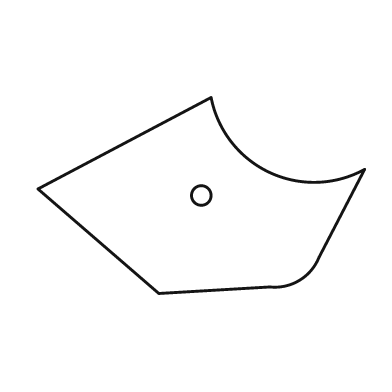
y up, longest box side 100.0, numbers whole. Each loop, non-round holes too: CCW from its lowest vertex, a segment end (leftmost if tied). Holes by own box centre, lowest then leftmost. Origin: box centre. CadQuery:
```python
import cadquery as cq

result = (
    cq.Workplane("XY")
    .moveTo(-13.0, -30.0)
    .lineTo(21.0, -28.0)
    .threePointArc((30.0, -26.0), (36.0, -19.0))
    .lineTo(50.0, 8.0)
    .threePointArc((21.0, 7.0), (3.0, 30.0))
    .lineTo(-50.0, 2.0)
    .close()
    .moveTo(0.0, 0.0)
    .circle(3.0)
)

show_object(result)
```